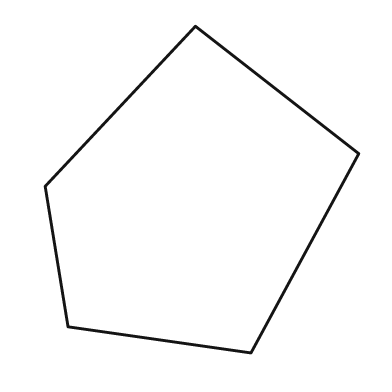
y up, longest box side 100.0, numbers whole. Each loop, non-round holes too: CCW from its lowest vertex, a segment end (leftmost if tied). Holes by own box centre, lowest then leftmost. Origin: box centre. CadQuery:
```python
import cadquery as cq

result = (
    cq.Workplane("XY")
    .moveTo(15.0, -50.0)
    .lineTo(48.0, 11.0)
    .lineTo(-2.0, 50.0)
    .lineTo(-48.0, 1.0)
    .lineTo(-41.0, -42.0)
    .close()
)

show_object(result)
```